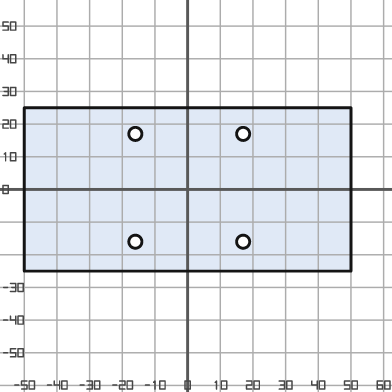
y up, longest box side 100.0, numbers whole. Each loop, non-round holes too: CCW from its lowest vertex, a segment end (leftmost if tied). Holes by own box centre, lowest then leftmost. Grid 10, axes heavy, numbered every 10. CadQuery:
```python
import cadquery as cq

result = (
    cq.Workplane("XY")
    .moveTo(-50.0, -25.0)
    .lineTo(50.0, -25.0)
    .lineTo(50.0, 25.0)
    .lineTo(-50.0, 25.0)
    .close()
    .moveTo(-16.0, -16.0)
    .circle(2.0)
    .moveTo(17.0, -16.0)
    .circle(2.0)
    .moveTo(-16.0, 17.0)
    .circle(2.0)
    .moveTo(17.0, 17.0)
    .circle(2.0)
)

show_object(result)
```